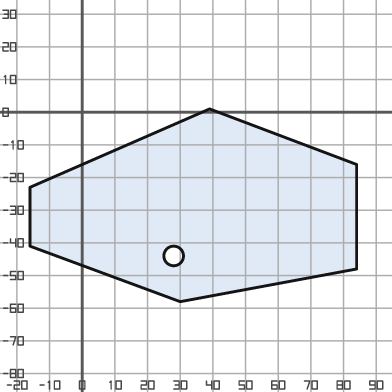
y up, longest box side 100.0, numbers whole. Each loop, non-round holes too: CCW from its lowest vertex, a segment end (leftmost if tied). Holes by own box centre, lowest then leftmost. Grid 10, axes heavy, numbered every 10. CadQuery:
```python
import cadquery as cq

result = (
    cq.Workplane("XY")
    .moveTo(30.0, -58.0)
    .lineTo(84.0, -48.0)
    .lineTo(84.0, -16.0)
    .lineTo(39.0, 1.0)
    .lineTo(-16.0, -23.0)
    .lineTo(-16.0, -41.0)
    .close()
    .moveTo(28.0, -44.0)
    .circle(3.0)
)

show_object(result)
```